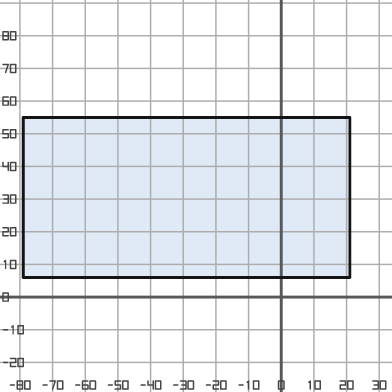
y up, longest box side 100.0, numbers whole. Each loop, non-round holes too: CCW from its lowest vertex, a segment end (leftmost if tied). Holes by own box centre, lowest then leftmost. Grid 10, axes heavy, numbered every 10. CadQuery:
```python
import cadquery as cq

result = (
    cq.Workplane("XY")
    .moveTo(-79.0, 6.0)
    .lineTo(21.0, 6.0)
    .lineTo(21.0, 55.0)
    .lineTo(-79.0, 55.0)
    .close()
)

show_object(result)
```